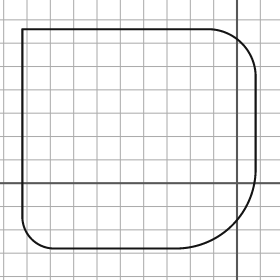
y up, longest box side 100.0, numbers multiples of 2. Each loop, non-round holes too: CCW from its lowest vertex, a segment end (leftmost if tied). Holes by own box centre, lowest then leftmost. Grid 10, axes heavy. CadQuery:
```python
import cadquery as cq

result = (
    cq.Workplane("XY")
    .moveTo(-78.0, -28.0)
    .lineTo(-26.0, -28.0)
    .threePointArc((-2.0, -18.0), (8.0, 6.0))
    .lineTo(8.0, 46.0)
    .threePointArc((2.0, 60.0), (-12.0, 66.0))
    .lineTo(-92.0, 66.0)
    .lineTo(-92.0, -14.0)
    .threePointArc((-88.0, -24.0), (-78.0, -28.0))
    .close()
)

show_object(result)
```